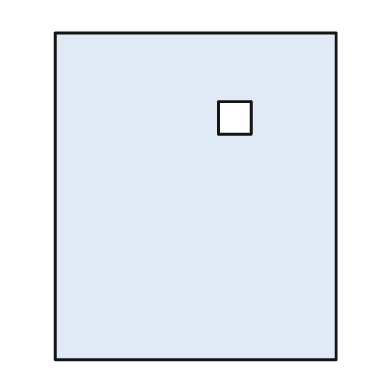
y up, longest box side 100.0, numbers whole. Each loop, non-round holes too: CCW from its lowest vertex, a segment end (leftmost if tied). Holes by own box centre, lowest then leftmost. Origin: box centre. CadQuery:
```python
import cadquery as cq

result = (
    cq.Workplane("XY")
    .moveTo(-43.0, -50.0)
    .lineTo(43.0, -50.0)
    .lineTo(43.0, 50.0)
    .lineTo(-43.0, 50.0)
    .close()
    .moveTo(7.0, 19.0)
    .lineTo(17.0, 19.0)
    .lineTo(17.0, 29.0)
    .lineTo(7.0, 29.0)
    .close()
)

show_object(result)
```